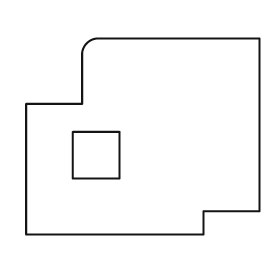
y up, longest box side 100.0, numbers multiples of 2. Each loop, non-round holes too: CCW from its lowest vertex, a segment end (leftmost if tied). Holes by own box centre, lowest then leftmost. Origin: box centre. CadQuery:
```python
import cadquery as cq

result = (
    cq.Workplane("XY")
    .moveTo(-50.0, -42.0)
    .lineTo(26.0, -42.0)
    .lineTo(26.0, -32.0)
    .lineTo(50.0, -32.0)
    .lineTo(50.0, 42.0)
    .lineTo(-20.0, 42.0)
    .threePointArc((-24.0, 40.0), (-26.0, 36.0))
    .lineTo(-26.0, 14.0)
    .lineTo(-50.0, 14.0)
    .close()
    .moveTo(-30.0, -18.0)
    .lineTo(-10.0, -18.0)
    .lineTo(-10.0, 2.0)
    .lineTo(-30.0, 2.0)
    .close()
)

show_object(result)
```